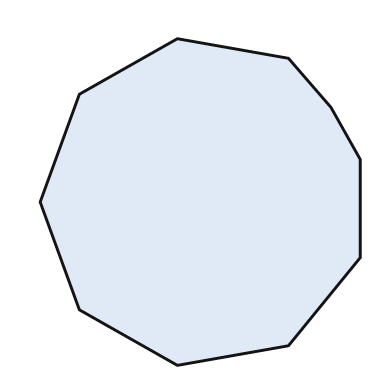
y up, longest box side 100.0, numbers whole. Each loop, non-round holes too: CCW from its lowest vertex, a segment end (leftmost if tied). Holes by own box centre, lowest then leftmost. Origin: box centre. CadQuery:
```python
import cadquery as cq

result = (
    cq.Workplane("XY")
    .moveTo(-7.0, -50.0)
    .lineTo(27.0, -44.0)
    .lineTo(49.0, -17.0)
    .lineTo(49.0, 13.0)
    .lineTo(40.0, 29.0)
    .lineTo(27.0, 44.0)
    .lineTo(-7.0, 50.0)
    .lineTo(-37.0, 33.0)
    .lineTo(-49.0, 0.0)
    .lineTo(-37.0, -33.0)
    .close()
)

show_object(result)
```